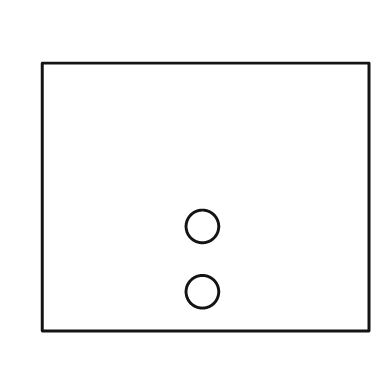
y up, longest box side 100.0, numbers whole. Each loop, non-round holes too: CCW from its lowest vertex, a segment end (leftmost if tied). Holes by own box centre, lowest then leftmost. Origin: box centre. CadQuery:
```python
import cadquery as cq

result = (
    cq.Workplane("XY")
    .moveTo(-50.0, -41.0)
    .lineTo(50.0, -41.0)
    .lineTo(50.0, 41.0)
    .lineTo(-50.0, 41.0)
    .close()
    .moveTo(-1.0, -29.0)
    .circle(5.0)
    .moveTo(-1.0, -9.0)
    .circle(5.0)
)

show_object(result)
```